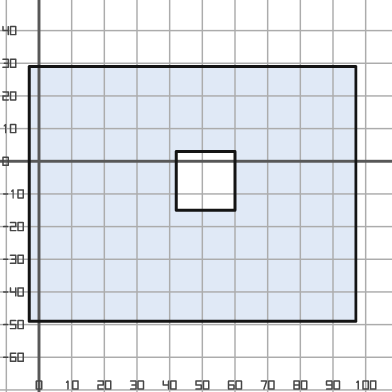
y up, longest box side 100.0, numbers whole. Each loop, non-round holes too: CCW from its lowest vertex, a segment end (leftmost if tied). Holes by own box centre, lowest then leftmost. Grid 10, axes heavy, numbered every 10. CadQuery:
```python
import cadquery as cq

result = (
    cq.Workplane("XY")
    .moveTo(-3.0, -49.0)
    .lineTo(97.0, -49.0)
    .lineTo(97.0, 29.0)
    .lineTo(-3.0, 29.0)
    .close()
    .moveTo(42.0, -15.0)
    .lineTo(60.0, -15.0)
    .lineTo(60.0, 3.0)
    .lineTo(42.0, 3.0)
    .close()
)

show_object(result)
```